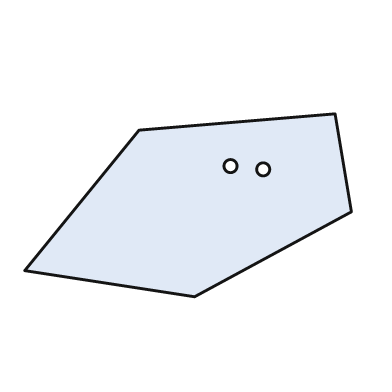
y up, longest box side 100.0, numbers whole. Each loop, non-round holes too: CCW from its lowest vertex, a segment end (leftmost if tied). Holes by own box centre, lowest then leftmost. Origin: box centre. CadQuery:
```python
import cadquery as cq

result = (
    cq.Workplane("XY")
    .moveTo(2.0, -28.0)
    .lineTo(50.0, -2.0)
    .lineTo(45.0, 28.0)
    .lineTo(-15.0, 23.0)
    .lineTo(-50.0, -20.0)
    .close()
    .moveTo(23.0, 11.0)
    .circle(2.0)
    .moveTo(13.0, 12.0)
    .circle(2.0)
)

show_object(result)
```